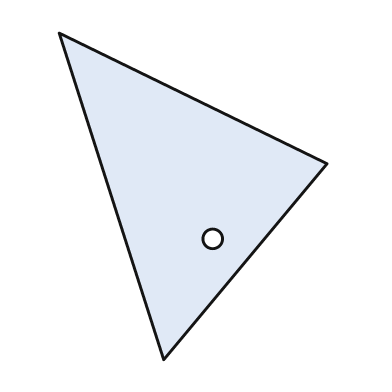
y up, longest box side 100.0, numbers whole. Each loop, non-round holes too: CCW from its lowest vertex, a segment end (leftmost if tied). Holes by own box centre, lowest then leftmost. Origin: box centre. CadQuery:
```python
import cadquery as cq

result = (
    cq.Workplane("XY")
    .moveTo(-9.0, -50.0)
    .lineTo(41.0, 10.0)
    .lineTo(-41.0, 50.0)
    .close()
    .moveTo(6.0, -13.0)
    .circle(3.0)
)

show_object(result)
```